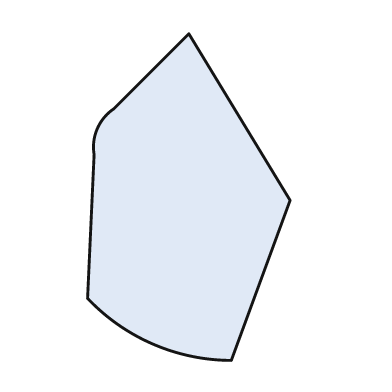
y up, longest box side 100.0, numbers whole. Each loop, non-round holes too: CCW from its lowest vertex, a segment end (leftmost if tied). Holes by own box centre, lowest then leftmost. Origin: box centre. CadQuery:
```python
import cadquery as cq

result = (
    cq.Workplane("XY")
    .moveTo(13.0, -50.0)
    .lineTo(31.0, -1.0)
    .lineTo(0.0, 50.0)
    .lineTo(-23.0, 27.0)
    .threePointArc((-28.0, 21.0), (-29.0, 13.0))
    .lineTo(-31.0, -31.0)
    .threePointArc((-11.0, -45.0), (13.0, -50.0))
    .close()
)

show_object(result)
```